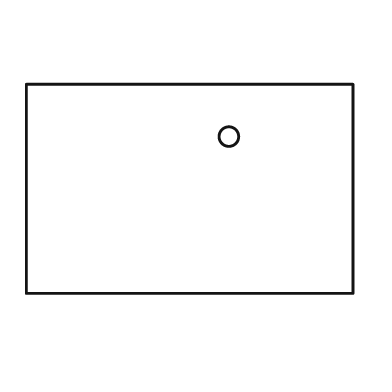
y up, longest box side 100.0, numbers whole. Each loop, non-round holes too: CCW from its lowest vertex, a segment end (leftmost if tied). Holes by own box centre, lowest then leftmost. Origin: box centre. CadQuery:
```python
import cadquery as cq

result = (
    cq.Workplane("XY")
    .moveTo(-50.0, -32.0)
    .lineTo(50.0, -32.0)
    .lineTo(50.0, 32.0)
    .lineTo(-50.0, 32.0)
    .close()
    .moveTo(12.0, 16.0)
    .circle(3.0)
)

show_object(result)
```